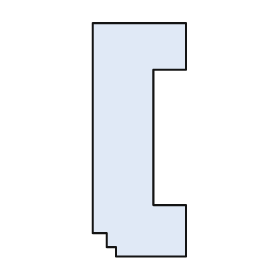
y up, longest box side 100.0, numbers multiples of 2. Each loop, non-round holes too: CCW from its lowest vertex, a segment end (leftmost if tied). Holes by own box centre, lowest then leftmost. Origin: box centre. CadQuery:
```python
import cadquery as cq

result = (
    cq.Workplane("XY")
    .moveTo(-10.0, -50.0)
    .lineTo(20.0, -50.0)
    .lineTo(20.0, -28.0)
    .lineTo(6.0, -28.0)
    .lineTo(6.0, 30.0)
    .lineTo(20.0, 30.0)
    .lineTo(20.0, 50.0)
    .lineTo(-20.0, 50.0)
    .lineTo(-20.0, -40.0)
    .lineTo(-14.0, -40.0)
    .lineTo(-14.0, -46.0)
    .lineTo(-10.0, -46.0)
    .close()
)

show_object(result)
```